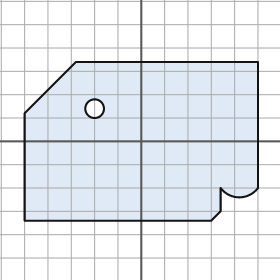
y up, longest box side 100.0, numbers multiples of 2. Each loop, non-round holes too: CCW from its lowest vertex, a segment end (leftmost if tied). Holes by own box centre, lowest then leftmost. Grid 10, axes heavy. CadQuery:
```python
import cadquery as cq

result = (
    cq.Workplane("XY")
    .moveTo(-50.0, -34.0)
    .lineTo(30.0, -34.0)
    .lineTo(34.0, -30.0)
    .lineTo(34.0, -20.0)
    .threePointArc((42.0, -24.0), (50.0, -20.0))
    .lineTo(50.0, 34.0)
    .lineTo(-28.0, 34.0)
    .lineTo(-50.0, 12.0)
    .close()
    .moveTo(-20.0, 14.0)
    .circle(4.0)
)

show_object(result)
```